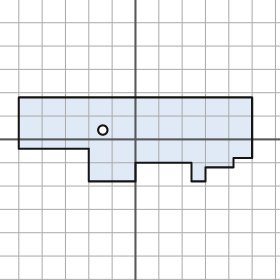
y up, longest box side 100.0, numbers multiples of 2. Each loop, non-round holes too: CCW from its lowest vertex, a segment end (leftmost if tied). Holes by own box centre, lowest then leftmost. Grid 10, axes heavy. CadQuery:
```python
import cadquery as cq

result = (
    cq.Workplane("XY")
    .moveTo(-20.0, -18.0)
    .lineTo(0.0, -18.0)
    .lineTo(0.0, -10.0)
    .lineTo(24.0, -10.0)
    .lineTo(24.0, -18.0)
    .lineTo(30.0, -18.0)
    .lineTo(30.0, -12.0)
    .lineTo(42.0, -12.0)
    .lineTo(42.0, -8.0)
    .lineTo(50.0, -8.0)
    .lineTo(50.0, 18.0)
    .lineTo(-50.0, 18.0)
    .lineTo(-50.0, -4.0)
    .lineTo(-20.0, -4.0)
    .close()
    .moveTo(-14.0, 4.0)
    .circle(2.0)
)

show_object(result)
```